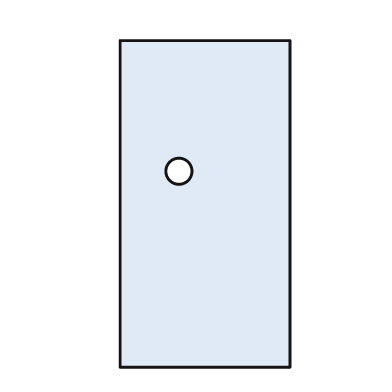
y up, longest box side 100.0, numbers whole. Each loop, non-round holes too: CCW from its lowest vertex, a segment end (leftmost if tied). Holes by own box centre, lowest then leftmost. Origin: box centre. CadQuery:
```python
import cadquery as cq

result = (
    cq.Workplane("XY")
    .moveTo(-26.0, -50.0)
    .lineTo(26.0, -50.0)
    .lineTo(26.0, 50.0)
    .lineTo(-26.0, 50.0)
    .close()
    .moveTo(-8.0, 10.0)
    .circle(4.0)
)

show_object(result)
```